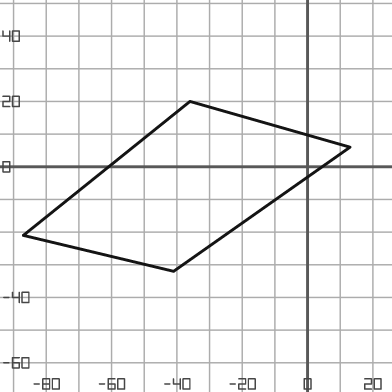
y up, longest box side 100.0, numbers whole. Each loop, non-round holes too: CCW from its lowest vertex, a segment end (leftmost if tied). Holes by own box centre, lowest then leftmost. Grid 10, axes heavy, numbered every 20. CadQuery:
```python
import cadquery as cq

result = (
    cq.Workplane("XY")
    .moveTo(-41.0, -32.0)
    .lineTo(13.0, 6.0)
    .lineTo(-36.0, 20.0)
    .lineTo(-87.0, -21.0)
    .close()
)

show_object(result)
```